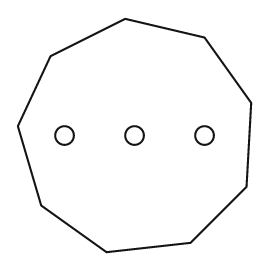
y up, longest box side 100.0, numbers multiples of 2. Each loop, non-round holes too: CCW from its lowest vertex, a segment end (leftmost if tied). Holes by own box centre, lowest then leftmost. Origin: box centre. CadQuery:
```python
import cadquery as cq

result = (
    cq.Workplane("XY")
    .moveTo(-12.0, -50.0)
    .lineTo(24.0, -46.0)
    .lineTo(48.0, -22.0)
    .lineTo(50.0, 14.0)
    .lineTo(30.0, 42.0)
    .lineTo(-4.0, 50.0)
    .lineTo(-36.0, 34.0)
    .lineTo(-50.0, 4.0)
    .lineTo(-40.0, -30.0)
    .close()
    .moveTo(-30.0, 0.0)
    .circle(4.0)
    .moveTo(0.0, 0.0)
    .circle(4.0)
    .moveTo(30.0, 0.0)
    .circle(4.0)
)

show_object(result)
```